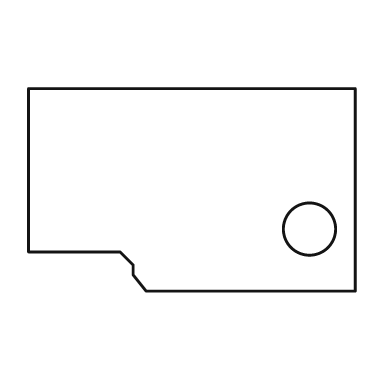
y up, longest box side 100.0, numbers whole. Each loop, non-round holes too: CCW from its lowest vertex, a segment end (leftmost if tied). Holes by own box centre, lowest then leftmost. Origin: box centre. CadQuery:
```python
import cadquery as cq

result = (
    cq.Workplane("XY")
    .moveTo(-14.0, -31.0)
    .lineTo(50.0, -31.0)
    .lineTo(50.0, 31.0)
    .lineTo(-50.0, 31.0)
    .lineTo(-50.0, -19.0)
    .lineTo(-22.0, -19.0)
    .lineTo(-18.0, -23.0)
    .lineTo(-18.0, -26.0)
    .close()
    .moveTo(36.0, -12.0)
    .circle(8.0)
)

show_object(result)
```